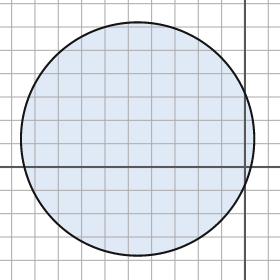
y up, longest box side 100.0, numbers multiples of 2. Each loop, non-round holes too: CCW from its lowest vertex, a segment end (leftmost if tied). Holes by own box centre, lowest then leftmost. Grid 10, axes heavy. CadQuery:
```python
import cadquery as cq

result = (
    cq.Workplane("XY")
    .moveTo(-46.0, 12.0)
    .circle(50.0)
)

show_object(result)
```